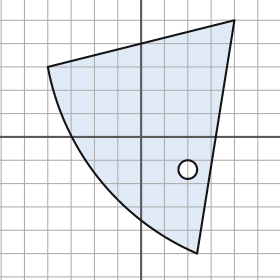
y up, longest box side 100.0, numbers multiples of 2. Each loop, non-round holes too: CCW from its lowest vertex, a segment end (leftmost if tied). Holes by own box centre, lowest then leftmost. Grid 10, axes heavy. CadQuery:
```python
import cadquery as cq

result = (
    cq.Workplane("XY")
    .moveTo(24.0, -50.0)
    .lineTo(40.0, 50.0)
    .lineTo(-40.0, 30.0)
    .threePointArc((-18.0, -18.0), (24.0, -50.0))
    .close()
    .moveTo(20.0, -14.0)
    .circle(4.0)
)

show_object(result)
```